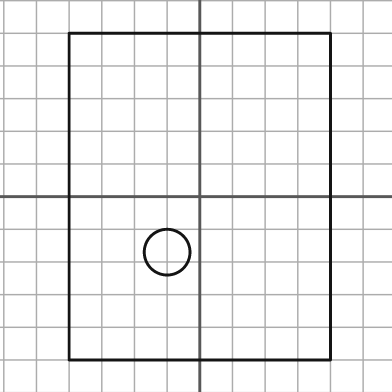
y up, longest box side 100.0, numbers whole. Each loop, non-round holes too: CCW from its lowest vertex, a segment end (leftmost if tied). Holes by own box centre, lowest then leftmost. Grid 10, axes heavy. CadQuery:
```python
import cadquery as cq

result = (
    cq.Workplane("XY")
    .moveTo(-40.0, -50.0)
    .lineTo(40.0, -50.0)
    .lineTo(40.0, 50.0)
    .lineTo(-40.0, 50.0)
    .close()
    .moveTo(-10.0, -17.0)
    .circle(7.0)
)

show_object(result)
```